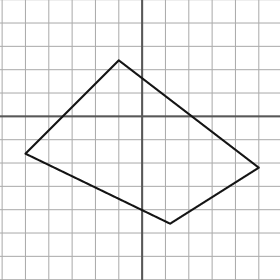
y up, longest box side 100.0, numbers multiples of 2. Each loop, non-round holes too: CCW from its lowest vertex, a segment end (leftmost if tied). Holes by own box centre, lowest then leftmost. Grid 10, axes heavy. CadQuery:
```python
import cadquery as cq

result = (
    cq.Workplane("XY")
    .moveTo(12.0, -46.0)
    .lineTo(50.0, -22.0)
    .lineTo(-10.0, 24.0)
    .lineTo(-50.0, -16.0)
    .close()
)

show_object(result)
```